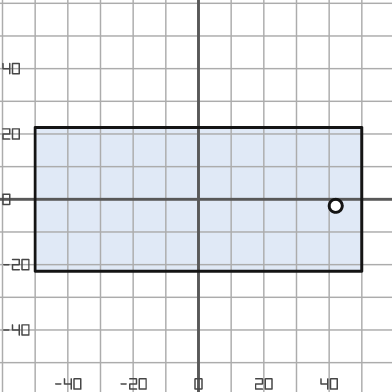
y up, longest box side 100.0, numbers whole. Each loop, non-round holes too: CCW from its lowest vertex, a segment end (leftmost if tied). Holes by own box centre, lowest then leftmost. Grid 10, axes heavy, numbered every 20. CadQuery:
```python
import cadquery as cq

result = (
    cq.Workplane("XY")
    .moveTo(-50.0, -22.0)
    .lineTo(50.0, -22.0)
    .lineTo(50.0, 22.0)
    .lineTo(-50.0, 22.0)
    .close()
    .moveTo(42.0, -2.0)
    .circle(2.0)
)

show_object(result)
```